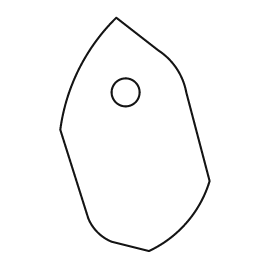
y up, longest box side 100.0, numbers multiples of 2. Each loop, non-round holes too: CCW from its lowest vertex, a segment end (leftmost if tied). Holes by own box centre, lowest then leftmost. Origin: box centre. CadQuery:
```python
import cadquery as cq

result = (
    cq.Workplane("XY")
    .moveTo(6.0, -50.0)
    .threePointArc((22.0, -38.0), (32.0, -20.0))
    .lineTo(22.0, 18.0)
    .threePointArc((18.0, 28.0), (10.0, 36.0))
    .lineTo(-8.0, 50.0)
    .threePointArc((-24.0, 28.0), (-32.0, 2.0))
    .lineTo(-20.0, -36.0)
    .threePointArc((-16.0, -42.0), (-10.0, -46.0))
    .close()
    .moveTo(-4.0, 18.0)
    .circle(6.0)
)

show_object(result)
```